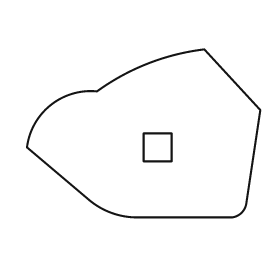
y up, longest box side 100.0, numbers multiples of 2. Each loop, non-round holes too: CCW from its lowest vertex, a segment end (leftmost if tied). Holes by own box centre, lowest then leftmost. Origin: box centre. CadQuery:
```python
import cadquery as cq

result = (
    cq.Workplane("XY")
    .moveTo(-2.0, -36.0)
    .lineTo(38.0, -36.0)
    .threePointArc((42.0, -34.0), (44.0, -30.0))
    .lineTo(50.0, 10.0)
    .lineTo(26.0, 36.0)
    .threePointArc((2.0, 30.0), (-20.0, 18.0))
    .threePointArc((-40.0, 12.0), (-50.0, -6.0))
    .lineTo(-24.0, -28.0)
    .threePointArc((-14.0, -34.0), (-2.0, -36.0))
    .close()
    .moveTo(0.0, -12.0)
    .lineTo(12.0, -12.0)
    .lineTo(12.0, 0.0)
    .lineTo(0.0, 0.0)
    .close()
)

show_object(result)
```